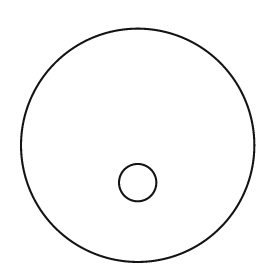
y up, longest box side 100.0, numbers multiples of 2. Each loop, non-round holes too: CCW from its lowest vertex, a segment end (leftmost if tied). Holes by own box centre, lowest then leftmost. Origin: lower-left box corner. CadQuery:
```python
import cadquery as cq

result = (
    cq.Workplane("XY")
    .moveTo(50.0, 50.0)
    .circle(50.0)
    .moveTo(50.0, 34.0)
    .circle(8.0)
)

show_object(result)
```